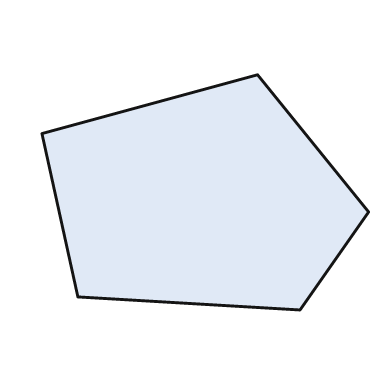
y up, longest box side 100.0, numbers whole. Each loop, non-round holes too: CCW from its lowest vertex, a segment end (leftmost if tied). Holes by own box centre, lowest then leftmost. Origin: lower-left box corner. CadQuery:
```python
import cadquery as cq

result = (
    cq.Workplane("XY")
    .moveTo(79.0, 0.0)
    .lineTo(100.0, 30.0)
    .lineTo(66.0, 72.0)
    .lineTo(0.0, 54.0)
    .lineTo(11.0, 4.0)
    .close()
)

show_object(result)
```